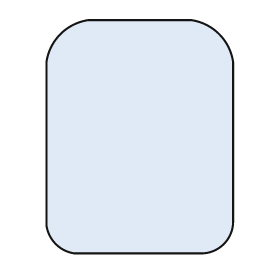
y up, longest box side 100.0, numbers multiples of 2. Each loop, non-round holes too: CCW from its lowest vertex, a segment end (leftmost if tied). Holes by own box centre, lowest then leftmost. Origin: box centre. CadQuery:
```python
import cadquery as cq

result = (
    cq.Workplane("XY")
    .moveTo(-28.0, -50.0)
    .lineTo(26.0, -50.0)
    .threePointArc((36.0, -46.0), (40.0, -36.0))
    .lineTo(40.0, 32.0)
    .threePointArc((34.0, 44.0), (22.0, 50.0))
    .lineTo(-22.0, 50.0)
    .threePointArc((-34.0, 44.0), (-40.0, 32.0))
    .lineTo(-40.0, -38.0)
    .threePointArc((-36.0, -46.0), (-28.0, -50.0))
    .close()
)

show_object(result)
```